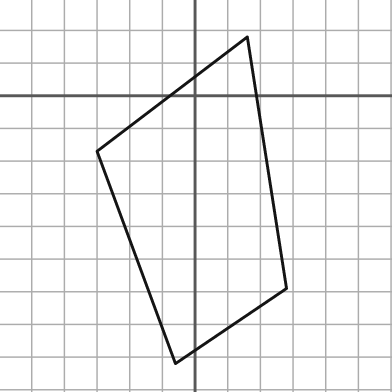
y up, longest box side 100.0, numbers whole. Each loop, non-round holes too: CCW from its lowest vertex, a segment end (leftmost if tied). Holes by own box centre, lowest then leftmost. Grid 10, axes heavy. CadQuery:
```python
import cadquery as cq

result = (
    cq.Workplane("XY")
    .moveTo(-6.0, -82.0)
    .lineTo(28.0, -59.0)
    .lineTo(16.0, 18.0)
    .lineTo(-30.0, -17.0)
    .close()
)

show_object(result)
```